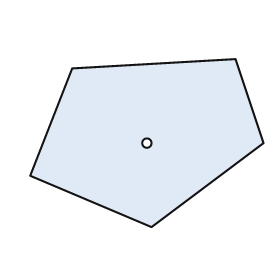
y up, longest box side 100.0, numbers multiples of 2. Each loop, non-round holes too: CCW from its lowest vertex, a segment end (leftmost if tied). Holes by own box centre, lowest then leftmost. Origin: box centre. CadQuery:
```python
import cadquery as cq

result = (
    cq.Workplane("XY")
    .moveTo(2.0, -36.0)
    .lineTo(50.0, 0.0)
    .lineTo(38.0, 36.0)
    .lineTo(-32.0, 32.0)
    .lineTo(-50.0, -14.0)
    .close()
    .moveTo(0.0, 0.0)
    .circle(2.0)
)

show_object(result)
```